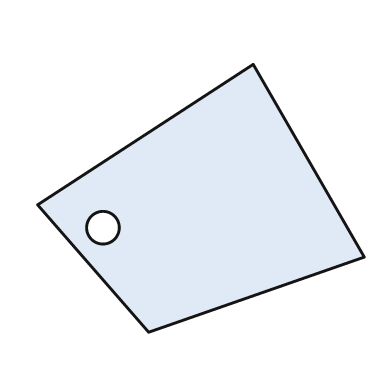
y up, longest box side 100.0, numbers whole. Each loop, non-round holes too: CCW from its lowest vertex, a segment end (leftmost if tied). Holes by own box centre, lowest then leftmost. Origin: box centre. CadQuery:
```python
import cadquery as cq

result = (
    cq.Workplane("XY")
    .moveTo(-16.0, -41.0)
    .lineTo(50.0, -18.0)
    .lineTo(16.0, 41.0)
    .lineTo(-50.0, -2.0)
    .close()
    .moveTo(-30.0, -9.0)
    .circle(5.0)
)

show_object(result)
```